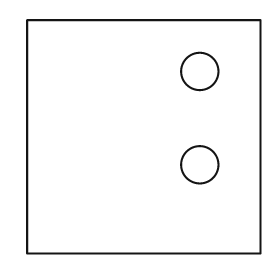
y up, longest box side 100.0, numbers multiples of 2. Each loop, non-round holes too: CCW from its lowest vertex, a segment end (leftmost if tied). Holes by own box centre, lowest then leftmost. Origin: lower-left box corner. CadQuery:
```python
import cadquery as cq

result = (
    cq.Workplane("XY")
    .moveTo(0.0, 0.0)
    .lineTo(100.0, 0.0)
    .lineTo(100.0, 100.0)
    .lineTo(0.0, 100.0)
    .close()
    .moveTo(74.0, 38.0)
    .circle(8.0)
    .moveTo(74.0, 78.0)
    .circle(8.0)
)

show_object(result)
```